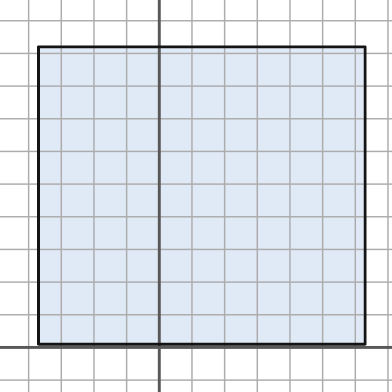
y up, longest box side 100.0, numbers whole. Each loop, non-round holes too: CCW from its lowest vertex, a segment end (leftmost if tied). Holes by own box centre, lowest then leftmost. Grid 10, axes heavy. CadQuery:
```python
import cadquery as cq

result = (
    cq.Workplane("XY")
    .moveTo(-37.0, 1.0)
    .lineTo(63.0, 1.0)
    .lineTo(63.0, 92.0)
    .lineTo(-37.0, 92.0)
    .close()
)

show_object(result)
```